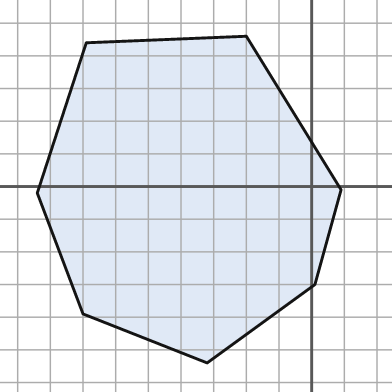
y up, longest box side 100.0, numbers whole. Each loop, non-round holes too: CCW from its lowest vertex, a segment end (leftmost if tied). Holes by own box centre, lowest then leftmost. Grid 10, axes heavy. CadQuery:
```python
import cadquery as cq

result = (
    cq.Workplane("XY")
    .moveTo(-32.0, -54.0)
    .lineTo(1.0, -30.0)
    .lineTo(9.0, -1.0)
    .lineTo(-20.0, 46.0)
    .lineTo(-69.0, 44.0)
    .lineTo(-84.0, -2.0)
    .lineTo(-70.0, -39.0)
    .close()
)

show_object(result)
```